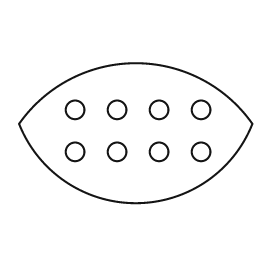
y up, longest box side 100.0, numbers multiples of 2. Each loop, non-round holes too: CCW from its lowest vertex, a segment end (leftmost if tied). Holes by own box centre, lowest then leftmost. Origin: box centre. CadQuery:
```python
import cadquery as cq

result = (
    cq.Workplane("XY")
    .moveTo(-50.0, 4.0)
    .threePointArc((0.0, -30.0), (50.0, 4.0))
    .threePointArc((0.0, 30.0), (-50.0, 4.0))
    .close()
    .moveTo(-26.0, -8.0)
    .circle(4.0)
    .moveTo(-8.0, -8.0)
    .circle(4.0)
    .moveTo(10.0, -8.0)
    .circle(4.0)
    .moveTo(28.0, -8.0)
    .circle(4.0)
    .moveTo(-26.0, 10.0)
    .circle(4.0)
    .moveTo(-8.0, 10.0)
    .circle(4.0)
    .moveTo(10.0, 10.0)
    .circle(4.0)
    .moveTo(28.0, 10.0)
    .circle(4.0)
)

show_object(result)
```